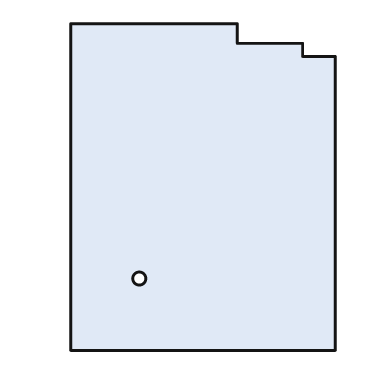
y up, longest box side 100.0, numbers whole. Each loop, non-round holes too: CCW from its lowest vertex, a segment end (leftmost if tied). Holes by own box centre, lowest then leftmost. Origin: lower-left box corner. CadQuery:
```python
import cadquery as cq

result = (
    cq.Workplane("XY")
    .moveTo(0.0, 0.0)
    .lineTo(81.0, 0.0)
    .lineTo(81.0, 90.0)
    .lineTo(71.0, 90.0)
    .lineTo(71.0, 94.0)
    .lineTo(51.0, 94.0)
    .lineTo(51.0, 100.0)
    .lineTo(0.0, 100.0)
    .close()
    .moveTo(21.0, 22.0)
    .circle(2.0)
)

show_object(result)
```